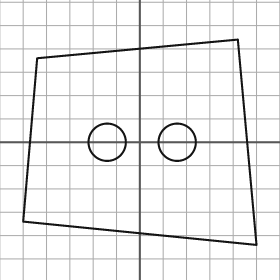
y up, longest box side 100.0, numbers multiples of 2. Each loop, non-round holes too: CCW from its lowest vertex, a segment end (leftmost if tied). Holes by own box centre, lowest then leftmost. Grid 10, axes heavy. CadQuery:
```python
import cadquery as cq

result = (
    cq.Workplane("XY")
    .moveTo(50.0, -44.0)
    .lineTo(42.0, 44.0)
    .lineTo(-44.0, 36.0)
    .lineTo(-50.0, -34.0)
    .close()
    .moveTo(-14.0, 0.0)
    .circle(8.0)
    .moveTo(16.0, 0.0)
    .circle(8.0)
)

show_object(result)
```